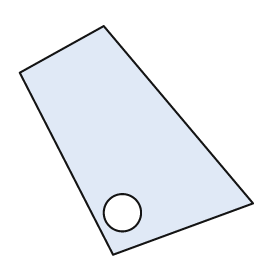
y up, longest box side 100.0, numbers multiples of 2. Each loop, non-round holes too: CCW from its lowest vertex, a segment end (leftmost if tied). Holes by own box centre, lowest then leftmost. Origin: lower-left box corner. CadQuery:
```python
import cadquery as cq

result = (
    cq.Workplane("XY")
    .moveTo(40.0, 0.0)
    .lineTo(100.0, 22.0)
    .lineTo(36.0, 98.0)
    .lineTo(0.0, 78.0)
    .close()
    .moveTo(44.0, 18.0)
    .circle(8.0)
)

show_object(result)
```